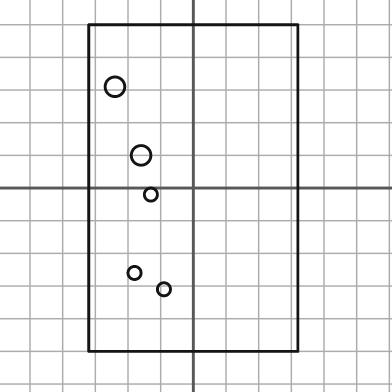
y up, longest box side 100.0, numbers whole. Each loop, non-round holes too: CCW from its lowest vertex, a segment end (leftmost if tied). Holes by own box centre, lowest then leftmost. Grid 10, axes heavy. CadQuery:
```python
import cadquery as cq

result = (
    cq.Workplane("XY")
    .moveTo(-32.0, -50.0)
    .lineTo(32.0, -50.0)
    .lineTo(32.0, 50.0)
    .lineTo(-32.0, 50.0)
    .close()
    .moveTo(-9.0, -31.0)
    .circle(2.0)
    .moveTo(-18.0, -26.0)
    .circle(2.0)
    .moveTo(-13.0, -2.0)
    .circle(2.0)
    .moveTo(-16.0, 10.0)
    .circle(3.0)
    .moveTo(-24.0, 31.0)
    .circle(3.0)
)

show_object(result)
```